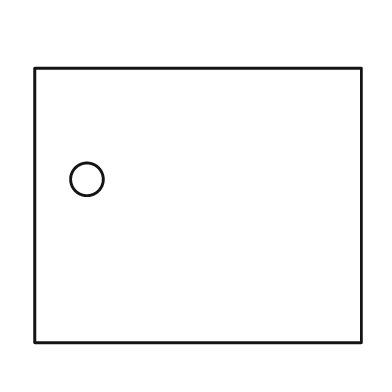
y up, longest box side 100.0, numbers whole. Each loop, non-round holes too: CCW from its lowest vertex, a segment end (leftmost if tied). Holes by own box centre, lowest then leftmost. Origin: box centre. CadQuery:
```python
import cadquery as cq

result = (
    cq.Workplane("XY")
    .moveTo(-50.0, -42.0)
    .lineTo(50.0, -42.0)
    .lineTo(50.0, 42.0)
    .lineTo(-50.0, 42.0)
    .close()
    .moveTo(-34.0, 8.0)
    .circle(5.0)
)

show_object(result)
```